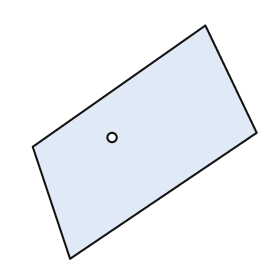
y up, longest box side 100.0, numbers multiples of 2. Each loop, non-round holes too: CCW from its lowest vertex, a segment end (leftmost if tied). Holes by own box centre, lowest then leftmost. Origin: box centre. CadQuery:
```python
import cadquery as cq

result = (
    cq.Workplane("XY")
    .moveTo(-32.0, -50.0)
    .lineTo(48.0, 4.0)
    .lineTo(26.0, 50.0)
    .lineTo(-48.0, -2.0)
    .close()
    .moveTo(-14.0, 2.0)
    .circle(2.0)
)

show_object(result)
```